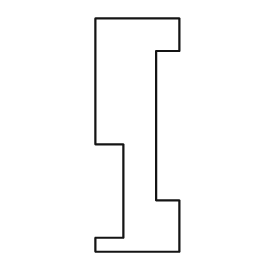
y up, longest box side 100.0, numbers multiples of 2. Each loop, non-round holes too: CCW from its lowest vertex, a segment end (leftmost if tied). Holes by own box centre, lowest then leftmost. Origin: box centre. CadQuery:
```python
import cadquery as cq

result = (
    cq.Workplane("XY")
    .moveTo(-18.0, -50.0)
    .lineTo(18.0, -50.0)
    .lineTo(18.0, -28.0)
    .lineTo(8.0, -28.0)
    .lineTo(8.0, 36.0)
    .lineTo(18.0, 36.0)
    .lineTo(18.0, 50.0)
    .lineTo(-18.0, 50.0)
    .lineTo(-18.0, -4.0)
    .lineTo(-6.0, -4.0)
    .lineTo(-6.0, -44.0)
    .lineTo(-18.0, -44.0)
    .close()
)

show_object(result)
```